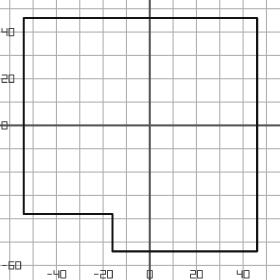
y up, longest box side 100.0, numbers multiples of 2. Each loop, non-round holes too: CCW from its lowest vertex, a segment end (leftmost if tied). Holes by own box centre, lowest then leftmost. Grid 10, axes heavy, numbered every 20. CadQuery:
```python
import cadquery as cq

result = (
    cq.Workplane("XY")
    .moveTo(-16.0, -54.0)
    .lineTo(46.0, -54.0)
    .lineTo(46.0, 46.0)
    .lineTo(-54.0, 46.0)
    .lineTo(-54.0, -38.0)
    .lineTo(-16.0, -38.0)
    .close()
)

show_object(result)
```